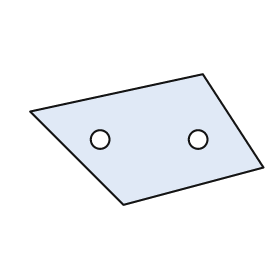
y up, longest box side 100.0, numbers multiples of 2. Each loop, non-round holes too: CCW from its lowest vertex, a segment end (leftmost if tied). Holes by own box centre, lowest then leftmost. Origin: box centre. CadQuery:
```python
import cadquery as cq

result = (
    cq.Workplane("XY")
    .moveTo(-10.0, -28.0)
    .lineTo(50.0, -12.0)
    .lineTo(24.0, 28.0)
    .lineTo(-50.0, 12.0)
    .close()
    .moveTo(-20.0, 0.0)
    .circle(4.0)
    .moveTo(22.0, 0.0)
    .circle(4.0)
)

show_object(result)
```